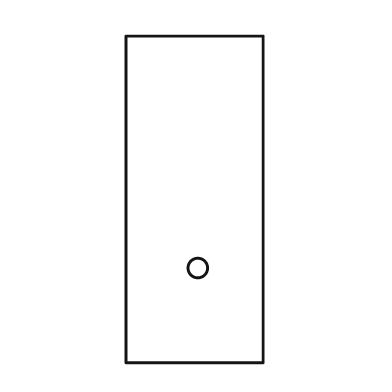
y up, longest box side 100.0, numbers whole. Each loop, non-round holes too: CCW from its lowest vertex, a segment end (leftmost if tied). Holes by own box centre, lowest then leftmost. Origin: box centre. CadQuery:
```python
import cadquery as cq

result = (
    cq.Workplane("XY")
    .moveTo(-21.0, -50.0)
    .lineTo(21.0, -50.0)
    .lineTo(21.0, 50.0)
    .lineTo(-21.0, 50.0)
    .close()
    .moveTo(1.0, -21.0)
    .circle(3.0)
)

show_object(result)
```